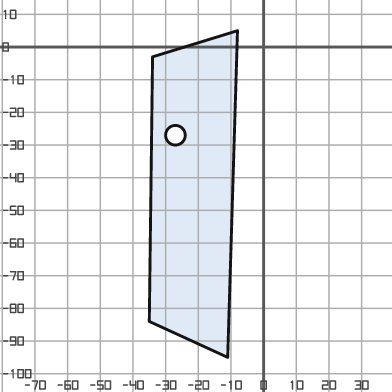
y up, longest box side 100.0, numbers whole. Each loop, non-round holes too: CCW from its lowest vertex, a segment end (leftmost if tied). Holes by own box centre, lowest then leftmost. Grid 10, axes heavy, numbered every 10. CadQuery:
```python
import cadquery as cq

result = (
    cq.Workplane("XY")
    .moveTo(-11.0, -95.0)
    .lineTo(-8.0, 5.0)
    .lineTo(-34.0, -3.0)
    .lineTo(-35.0, -84.0)
    .close()
    .moveTo(-27.0, -27.0)
    .circle(3.0)
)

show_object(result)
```